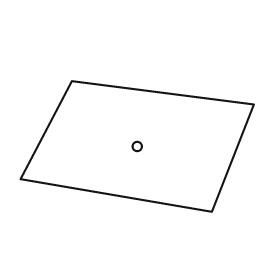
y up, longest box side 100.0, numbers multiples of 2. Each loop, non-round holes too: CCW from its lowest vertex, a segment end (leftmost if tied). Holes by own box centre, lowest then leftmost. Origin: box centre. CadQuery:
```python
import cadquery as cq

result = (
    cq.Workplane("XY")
    .moveTo(32.0, -28.0)
    .lineTo(50.0, 18.0)
    .lineTo(-28.0, 28.0)
    .lineTo(-50.0, -14.0)
    .close()
    .moveTo(0.0, 0.0)
    .circle(2.0)
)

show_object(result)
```